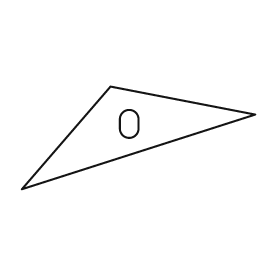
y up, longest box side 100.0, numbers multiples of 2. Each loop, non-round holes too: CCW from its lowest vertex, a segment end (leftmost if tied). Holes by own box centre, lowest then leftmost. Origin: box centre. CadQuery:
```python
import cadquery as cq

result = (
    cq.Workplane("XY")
    .moveTo(-50.0, -22.0)
    .lineTo(50.0, 10.0)
    .lineTo(-12.0, 22.0)
    .close()
    .moveTo(-8.0, 4.0)
    .threePointArc((-4.0, 0.0), (0.0, 4.0))
    .lineTo(0.0, 8.0)
    .threePointArc((-4.0, 12.0), (-8.0, 8.0))
    .close()
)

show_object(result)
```